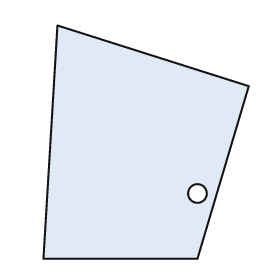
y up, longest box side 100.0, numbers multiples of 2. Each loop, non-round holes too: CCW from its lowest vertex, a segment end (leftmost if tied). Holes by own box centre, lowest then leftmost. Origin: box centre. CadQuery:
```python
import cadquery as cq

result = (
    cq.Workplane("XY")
    .moveTo(-44.0, -50.0)
    .lineTo(22.0, -50.0)
    .lineTo(44.0, 24.0)
    .lineTo(-38.0, 50.0)
    .close()
    .moveTo(22.0, -22.0)
    .circle(4.0)
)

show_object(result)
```